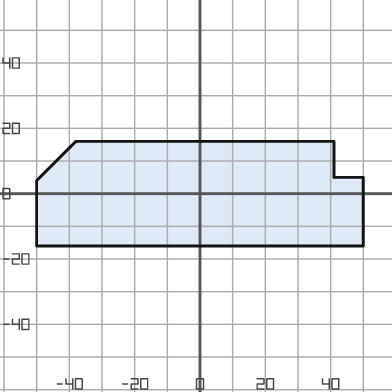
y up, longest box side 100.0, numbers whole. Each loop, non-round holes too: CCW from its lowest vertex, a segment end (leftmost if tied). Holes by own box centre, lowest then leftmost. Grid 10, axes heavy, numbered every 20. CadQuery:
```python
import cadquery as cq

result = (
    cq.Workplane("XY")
    .moveTo(-50.0, -16.0)
    .lineTo(50.0, -16.0)
    .lineTo(50.0, 5.0)
    .lineTo(41.0, 5.0)
    .lineTo(41.0, 16.0)
    .lineTo(-38.0, 16.0)
    .lineTo(-50.0, 4.0)
    .close()
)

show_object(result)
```